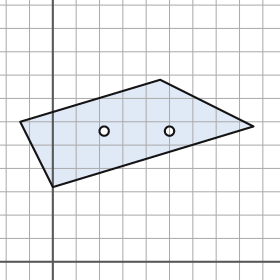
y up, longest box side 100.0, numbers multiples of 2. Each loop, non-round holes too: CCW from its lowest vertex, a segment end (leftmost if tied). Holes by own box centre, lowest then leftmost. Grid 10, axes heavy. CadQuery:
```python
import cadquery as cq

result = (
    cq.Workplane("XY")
    .moveTo(0.0, 32.0)
    .lineTo(86.0, 58.0)
    .lineTo(46.0, 78.0)
    .lineTo(-14.0, 60.0)
    .close()
    .moveTo(22.0, 56.0)
    .circle(2.0)
    .moveTo(50.0, 56.0)
    .circle(2.0)
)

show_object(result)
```